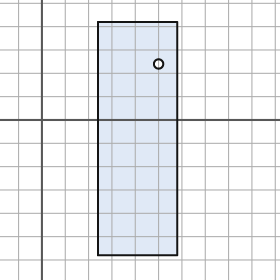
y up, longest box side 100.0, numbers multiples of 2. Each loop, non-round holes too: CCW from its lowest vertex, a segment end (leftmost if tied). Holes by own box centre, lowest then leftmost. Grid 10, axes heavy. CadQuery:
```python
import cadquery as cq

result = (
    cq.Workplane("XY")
    .moveTo(24.0, -58.0)
    .lineTo(58.0, -58.0)
    .lineTo(58.0, 42.0)
    .lineTo(24.0, 42.0)
    .close()
    .moveTo(50.0, 24.0)
    .circle(2.0)
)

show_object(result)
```